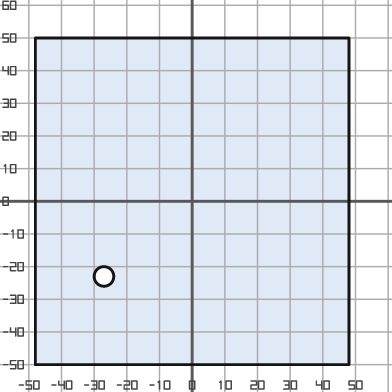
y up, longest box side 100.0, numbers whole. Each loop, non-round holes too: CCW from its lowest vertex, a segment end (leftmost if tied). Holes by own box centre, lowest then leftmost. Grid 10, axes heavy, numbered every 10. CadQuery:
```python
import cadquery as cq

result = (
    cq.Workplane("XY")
    .moveTo(-48.0, -50.0)
    .lineTo(48.0, -50.0)
    .lineTo(48.0, 50.0)
    .lineTo(-48.0, 50.0)
    .close()
    .moveTo(-27.0, -23.0)
    .circle(3.0)
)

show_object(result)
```